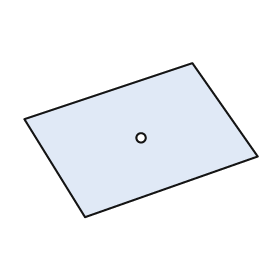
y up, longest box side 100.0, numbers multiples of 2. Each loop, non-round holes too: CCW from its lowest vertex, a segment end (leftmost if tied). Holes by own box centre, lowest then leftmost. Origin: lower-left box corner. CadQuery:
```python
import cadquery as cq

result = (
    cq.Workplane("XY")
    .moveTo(26.0, 0.0)
    .lineTo(100.0, 26.0)
    .lineTo(72.0, 66.0)
    .lineTo(0.0, 42.0)
    .close()
    .moveTo(50.0, 34.0)
    .circle(2.0)
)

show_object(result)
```